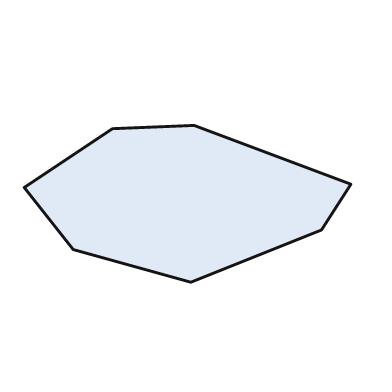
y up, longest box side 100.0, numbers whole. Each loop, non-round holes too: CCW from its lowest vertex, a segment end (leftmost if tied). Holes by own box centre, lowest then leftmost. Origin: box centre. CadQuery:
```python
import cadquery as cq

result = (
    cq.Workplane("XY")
    .moveTo(1.0, -24.0)
    .lineTo(41.0, -8.0)
    .lineTo(50.0, 6.0)
    .lineTo(2.0, 24.0)
    .lineTo(-23.0, 23.0)
    .lineTo(-50.0, 5.0)
    .lineTo(-35.0, -14.0)
    .close()
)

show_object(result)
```